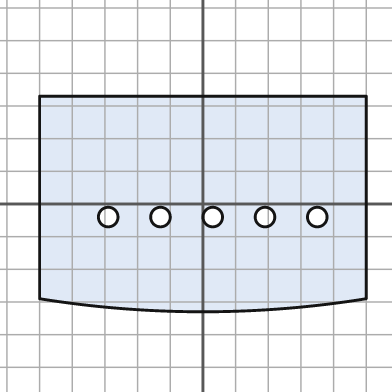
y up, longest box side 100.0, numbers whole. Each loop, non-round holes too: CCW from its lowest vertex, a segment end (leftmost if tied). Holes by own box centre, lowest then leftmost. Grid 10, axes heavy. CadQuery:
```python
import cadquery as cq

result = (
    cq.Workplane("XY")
    .moveTo(-50.0, -29.0)
    .threePointArc((0.0, -33.0), (50.0, -29.0))
    .lineTo(50.0, 33.0)
    .lineTo(-50.0, 33.0)
    .close()
    .moveTo(-29.0, -4.0)
    .circle(3.0)
    .moveTo(-13.0, -4.0)
    .circle(3.0)
    .moveTo(3.0, -4.0)
    .circle(3.0)
    .moveTo(19.0, -4.0)
    .circle(3.0)
    .moveTo(35.0, -4.0)
    .circle(3.0)
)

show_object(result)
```